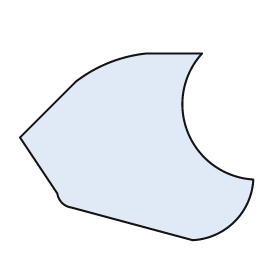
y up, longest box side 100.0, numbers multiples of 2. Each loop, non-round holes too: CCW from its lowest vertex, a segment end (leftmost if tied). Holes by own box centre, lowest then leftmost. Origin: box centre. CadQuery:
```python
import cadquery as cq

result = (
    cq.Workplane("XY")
    .moveTo(24.0, -40.0)
    .threePointArc((42.0, -32.0), (50.0, -14.0))
    .threePointArc((22.0, 6.0), (28.0, 40.0))
    .lineTo(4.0, 40.0)
    .threePointArc((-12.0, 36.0), (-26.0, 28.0))
    .lineTo(-50.0, 4.0)
    .lineTo(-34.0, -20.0)
    .threePointArc((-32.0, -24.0), (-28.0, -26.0))
    .close()
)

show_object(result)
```